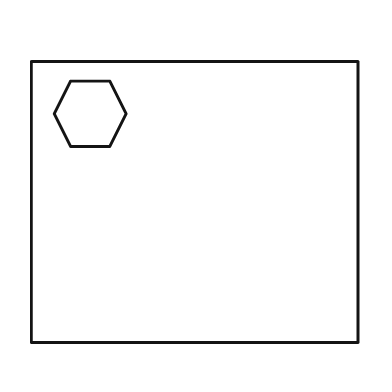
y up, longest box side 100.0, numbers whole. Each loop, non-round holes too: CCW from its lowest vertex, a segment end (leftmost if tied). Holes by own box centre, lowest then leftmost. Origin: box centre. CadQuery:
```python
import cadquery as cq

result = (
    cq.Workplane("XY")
    .moveTo(-50.0, -43.0)
    .lineTo(50.0, -43.0)
    .lineTo(50.0, 43.0)
    .lineTo(-50.0, 43.0)
    .close()
    .moveTo(-38.0, 17.0)
    .lineTo(-26.0, 17.0)
    .lineTo(-21.0, 27.0)
    .lineTo(-26.0, 37.0)
    .lineTo(-38.0, 37.0)
    .lineTo(-43.0, 27.0)
    .close()
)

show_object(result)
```